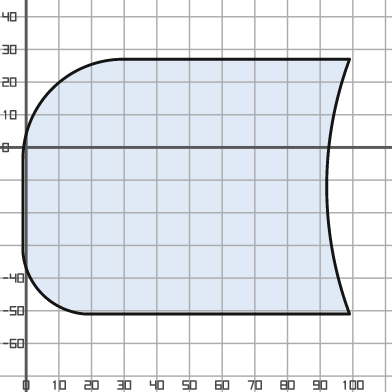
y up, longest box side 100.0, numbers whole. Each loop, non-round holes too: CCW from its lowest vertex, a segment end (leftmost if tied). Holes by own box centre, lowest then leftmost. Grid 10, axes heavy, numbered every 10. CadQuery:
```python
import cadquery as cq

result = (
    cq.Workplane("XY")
    .moveTo(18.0, -51.0)
    .lineTo(99.0, -51.0)
    .threePointArc((92.0, -12.0), (99.0, 27.0))
    .lineTo(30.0, 27.0)
    .threePointArc((8.0, 18.0), (-1.0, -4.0))
    .lineTo(-1.0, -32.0)
    .threePointArc((5.0, -45.0), (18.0, -51.0))
    .close()
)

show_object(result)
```